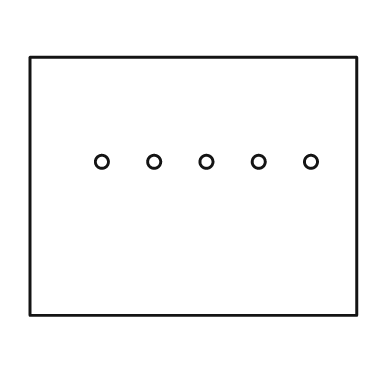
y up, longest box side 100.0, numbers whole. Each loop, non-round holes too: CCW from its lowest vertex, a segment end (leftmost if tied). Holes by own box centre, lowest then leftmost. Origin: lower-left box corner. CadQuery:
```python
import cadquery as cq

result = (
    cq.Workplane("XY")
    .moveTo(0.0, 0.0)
    .lineTo(100.0, 0.0)
    .lineTo(100.0, 79.0)
    .lineTo(0.0, 79.0)
    .close()
    .moveTo(22.0, 47.0)
    .circle(2.0)
    .moveTo(38.0, 47.0)
    .circle(2.0)
    .moveTo(54.0, 47.0)
    .circle(2.0)
    .moveTo(70.0, 47.0)
    .circle(2.0)
    .moveTo(86.0, 47.0)
    .circle(2.0)
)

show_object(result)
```